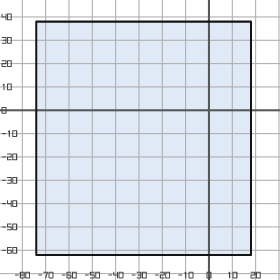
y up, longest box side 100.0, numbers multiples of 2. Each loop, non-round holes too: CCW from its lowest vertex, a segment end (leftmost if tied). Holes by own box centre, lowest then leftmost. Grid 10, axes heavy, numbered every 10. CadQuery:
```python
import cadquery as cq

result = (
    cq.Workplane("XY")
    .moveTo(-74.0, -62.0)
    .lineTo(18.0, -62.0)
    .lineTo(18.0, 38.0)
    .lineTo(-74.0, 38.0)
    .close()
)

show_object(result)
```